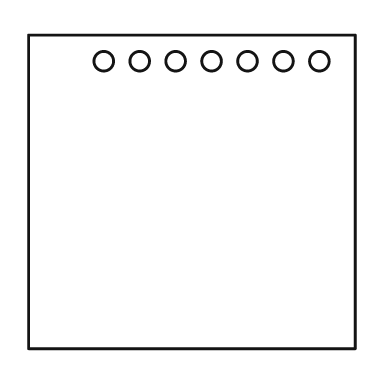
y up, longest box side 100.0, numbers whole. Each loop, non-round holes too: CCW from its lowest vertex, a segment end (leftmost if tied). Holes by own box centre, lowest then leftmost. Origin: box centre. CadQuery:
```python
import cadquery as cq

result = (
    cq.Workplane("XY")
    .moveTo(-50.0, -48.0)
    .lineTo(50.0, -48.0)
    .lineTo(50.0, 48.0)
    .lineTo(-50.0, 48.0)
    .close()
    .moveTo(-27.0, 40.0)
    .circle(3.0)
    .moveTo(-16.0, 40.0)
    .circle(3.0)
    .moveTo(-5.0, 40.0)
    .circle(3.0)
    .moveTo(6.0, 40.0)
    .circle(3.0)
    .moveTo(17.0, 40.0)
    .circle(3.0)
    .moveTo(28.0, 40.0)
    .circle(3.0)
    .moveTo(39.0, 40.0)
    .circle(3.0)
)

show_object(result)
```